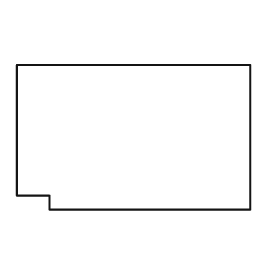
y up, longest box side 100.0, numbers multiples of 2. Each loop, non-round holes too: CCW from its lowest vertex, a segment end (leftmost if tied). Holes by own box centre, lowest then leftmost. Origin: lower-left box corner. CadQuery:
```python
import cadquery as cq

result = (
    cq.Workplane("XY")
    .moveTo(14.0, 0.0)
    .lineTo(100.0, 0.0)
    .lineTo(100.0, 62.0)
    .lineTo(0.0, 62.0)
    .lineTo(0.0, 6.0)
    .lineTo(14.0, 6.0)
    .close()
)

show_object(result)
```